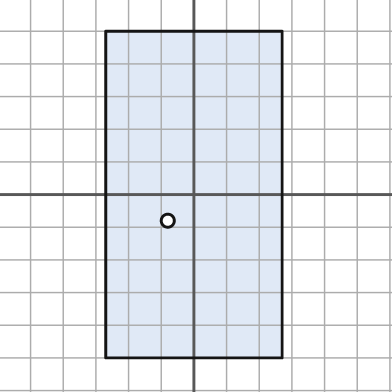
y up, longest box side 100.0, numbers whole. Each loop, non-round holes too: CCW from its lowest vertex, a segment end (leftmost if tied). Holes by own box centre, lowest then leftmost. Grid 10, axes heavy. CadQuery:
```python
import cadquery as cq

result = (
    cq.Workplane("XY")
    .moveTo(-27.0, -50.0)
    .lineTo(27.0, -50.0)
    .lineTo(27.0, 50.0)
    .lineTo(-27.0, 50.0)
    .close()
    .moveTo(-8.0, -8.0)
    .circle(2.0)
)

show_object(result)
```